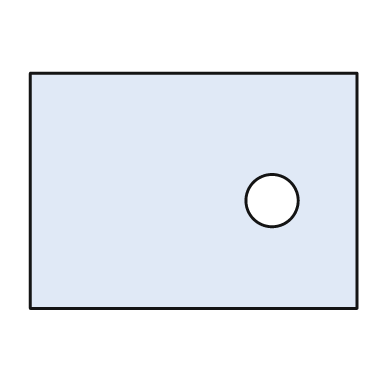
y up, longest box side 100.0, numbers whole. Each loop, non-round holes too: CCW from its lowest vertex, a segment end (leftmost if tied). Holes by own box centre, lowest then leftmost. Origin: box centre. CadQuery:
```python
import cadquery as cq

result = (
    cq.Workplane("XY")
    .moveTo(-50.0, -36.0)
    .lineTo(50.0, -36.0)
    .lineTo(50.0, 36.0)
    .lineTo(-50.0, 36.0)
    .close()
    .moveTo(24.0, -3.0)
    .circle(8.0)
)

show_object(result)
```